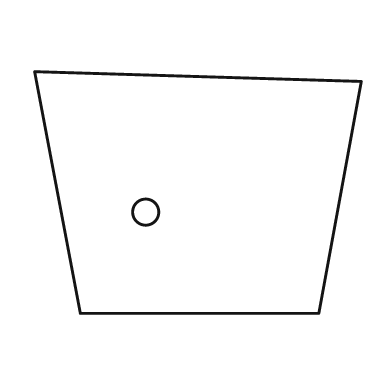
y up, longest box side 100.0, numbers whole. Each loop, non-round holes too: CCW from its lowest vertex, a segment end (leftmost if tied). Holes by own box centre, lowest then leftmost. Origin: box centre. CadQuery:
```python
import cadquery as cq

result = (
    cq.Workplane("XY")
    .moveTo(-36.0, -37.0)
    .lineTo(37.0, -37.0)
    .lineTo(50.0, 34.0)
    .lineTo(-50.0, 37.0)
    .close()
    .moveTo(-16.0, -6.0)
    .circle(4.0)
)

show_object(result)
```